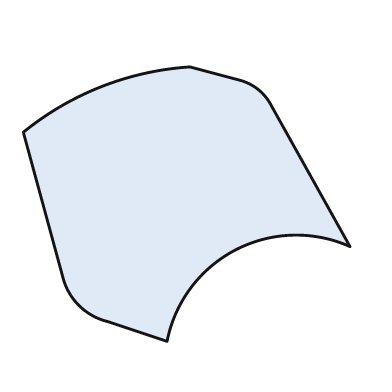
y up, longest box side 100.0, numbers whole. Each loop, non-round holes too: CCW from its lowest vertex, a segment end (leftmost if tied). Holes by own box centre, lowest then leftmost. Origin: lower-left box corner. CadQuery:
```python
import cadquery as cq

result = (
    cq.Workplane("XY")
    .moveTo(44.0, 0.0)
    .threePointArc((65.0, 28.0), (100.0, 29.0))
    .lineTo(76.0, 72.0)
    .threePointArc((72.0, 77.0), (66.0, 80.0))
    .lineTo(51.0, 84.0)
    .threePointArc((24.0, 78.0), (0.0, 64.0))
    .lineTo(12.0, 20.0)
    .threePointArc((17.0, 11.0), (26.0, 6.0))
    .close()
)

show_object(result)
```